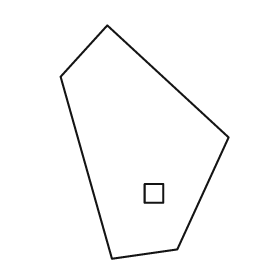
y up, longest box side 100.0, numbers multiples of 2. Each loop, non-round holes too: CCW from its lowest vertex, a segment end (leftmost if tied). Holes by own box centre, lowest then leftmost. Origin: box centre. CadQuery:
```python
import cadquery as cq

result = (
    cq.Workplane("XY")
    .moveTo(-14.0, -50.0)
    .lineTo(14.0, -46.0)
    .lineTo(36.0, 2.0)
    .lineTo(-16.0, 50.0)
    .lineTo(-36.0, 28.0)
    .close()
    .moveTo(0.0, -26.0)
    .lineTo(8.0, -26.0)
    .lineTo(8.0, -18.0)
    .lineTo(0.0, -18.0)
    .close()
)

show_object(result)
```